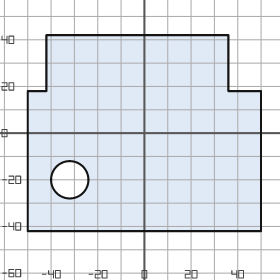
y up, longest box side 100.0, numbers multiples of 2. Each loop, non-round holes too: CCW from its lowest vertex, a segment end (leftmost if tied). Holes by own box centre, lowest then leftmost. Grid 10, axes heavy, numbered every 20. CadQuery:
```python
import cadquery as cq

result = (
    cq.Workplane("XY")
    .moveTo(-50.0, -42.0)
    .lineTo(50.0, -42.0)
    .lineTo(50.0, 18.0)
    .lineTo(36.0, 18.0)
    .lineTo(36.0, 42.0)
    .lineTo(-42.0, 42.0)
    .lineTo(-42.0, 18.0)
    .lineTo(-50.0, 18.0)
    .close()
    .moveTo(-32.0, -20.0)
    .circle(8.0)
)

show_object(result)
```